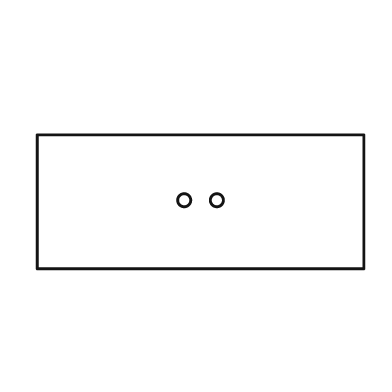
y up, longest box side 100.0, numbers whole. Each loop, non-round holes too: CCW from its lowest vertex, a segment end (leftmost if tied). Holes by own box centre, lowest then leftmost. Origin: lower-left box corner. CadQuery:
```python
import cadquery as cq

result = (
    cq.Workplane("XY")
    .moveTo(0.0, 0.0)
    .lineTo(100.0, 0.0)
    .lineTo(100.0, 41.0)
    .lineTo(0.0, 41.0)
    .close()
    .moveTo(45.0, 21.0)
    .circle(2.0)
    .moveTo(55.0, 21.0)
    .circle(2.0)
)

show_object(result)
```